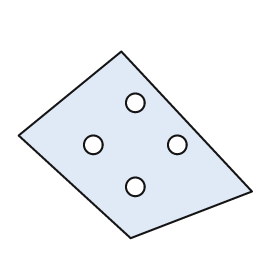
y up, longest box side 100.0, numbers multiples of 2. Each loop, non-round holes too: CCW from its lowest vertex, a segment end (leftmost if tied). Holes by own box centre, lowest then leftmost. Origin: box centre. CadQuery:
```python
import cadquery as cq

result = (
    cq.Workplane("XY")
    .moveTo(-2.0, -40.0)
    .lineTo(50.0, -20.0)
    .lineTo(-6.0, 40.0)
    .lineTo(-50.0, 4.0)
    .close()
    .moveTo(0.0, -18.0)
    .circle(4.0)
    .moveTo(-18.0, 0.0)
    .circle(4.0)
    .moveTo(18.0, 0.0)
    .circle(4.0)
    .moveTo(0.0, 18.0)
    .circle(4.0)
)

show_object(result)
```